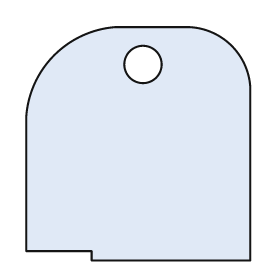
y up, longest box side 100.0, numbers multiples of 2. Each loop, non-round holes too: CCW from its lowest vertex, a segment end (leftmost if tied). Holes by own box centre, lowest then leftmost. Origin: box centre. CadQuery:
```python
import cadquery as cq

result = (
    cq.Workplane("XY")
    .moveTo(-20.0, -50.0)
    .lineTo(48.0, -50.0)
    .lineTo(48.0, 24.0)
    .threePointArc((40.0, 42.0), (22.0, 50.0))
    .lineTo(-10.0, 50.0)
    .threePointArc((-36.0, 38.0), (-48.0, 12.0))
    .lineTo(-48.0, -46.0)
    .lineTo(-20.0, -46.0)
    .close()
    .moveTo(2.0, 34.0)
    .circle(8.0)
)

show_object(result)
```